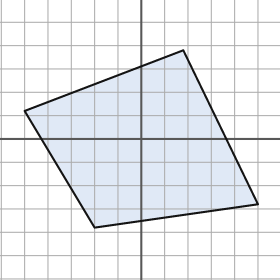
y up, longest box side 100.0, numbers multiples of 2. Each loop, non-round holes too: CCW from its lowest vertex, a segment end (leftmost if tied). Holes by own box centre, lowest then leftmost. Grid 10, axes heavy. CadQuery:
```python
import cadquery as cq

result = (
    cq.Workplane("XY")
    .moveTo(-20.0, -38.0)
    .lineTo(50.0, -28.0)
    .lineTo(18.0, 38.0)
    .lineTo(-50.0, 12.0)
    .close()
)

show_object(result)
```